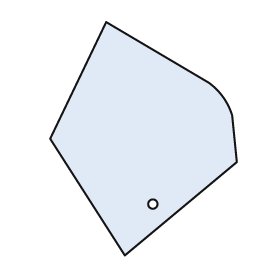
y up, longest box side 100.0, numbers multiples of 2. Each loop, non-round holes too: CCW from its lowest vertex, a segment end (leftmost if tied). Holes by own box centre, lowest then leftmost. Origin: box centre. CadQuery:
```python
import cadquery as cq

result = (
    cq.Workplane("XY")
    .moveTo(-8.0, -50.0)
    .lineTo(40.0, -10.0)
    .lineTo(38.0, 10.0)
    .threePointArc((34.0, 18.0), (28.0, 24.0))
    .lineTo(-16.0, 50.0)
    .lineTo(-40.0, 0.0)
    .close()
    .moveTo(4.0, -28.0)
    .circle(2.0)
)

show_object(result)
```